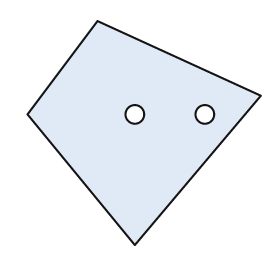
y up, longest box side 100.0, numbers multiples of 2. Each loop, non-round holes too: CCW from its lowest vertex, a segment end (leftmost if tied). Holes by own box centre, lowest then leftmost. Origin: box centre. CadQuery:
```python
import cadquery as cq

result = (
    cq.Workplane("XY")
    .moveTo(-4.0, -48.0)
    .lineTo(50.0, 16.0)
    .lineTo(-20.0, 48.0)
    .lineTo(-50.0, 8.0)
    .close()
    .moveTo(-4.0, 8.0)
    .circle(4.0)
    .moveTo(26.0, 8.0)
    .circle(4.0)
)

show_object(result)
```